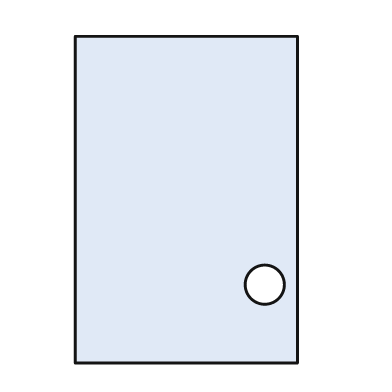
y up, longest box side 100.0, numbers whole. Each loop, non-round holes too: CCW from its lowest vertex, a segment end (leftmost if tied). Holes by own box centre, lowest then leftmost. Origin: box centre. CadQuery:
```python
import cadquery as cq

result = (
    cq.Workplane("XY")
    .moveTo(-34.0, -50.0)
    .lineTo(34.0, -50.0)
    .lineTo(34.0, 50.0)
    .lineTo(-34.0, 50.0)
    .close()
    .moveTo(24.0, -26.0)
    .circle(6.0)
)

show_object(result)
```